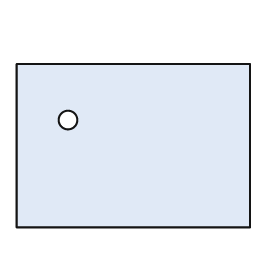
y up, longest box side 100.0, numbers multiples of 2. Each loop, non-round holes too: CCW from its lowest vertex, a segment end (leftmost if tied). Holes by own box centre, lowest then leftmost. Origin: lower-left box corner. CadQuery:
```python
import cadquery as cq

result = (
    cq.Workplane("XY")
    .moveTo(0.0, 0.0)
    .lineTo(100.0, 0.0)
    .lineTo(100.0, 70.0)
    .lineTo(0.0, 70.0)
    .close()
    .moveTo(22.0, 46.0)
    .circle(4.0)
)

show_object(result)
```